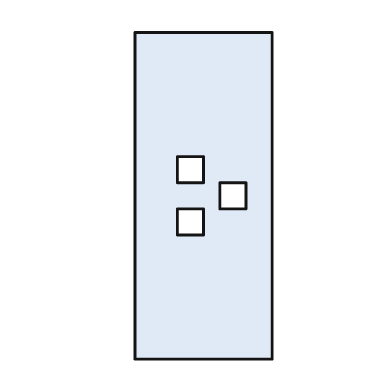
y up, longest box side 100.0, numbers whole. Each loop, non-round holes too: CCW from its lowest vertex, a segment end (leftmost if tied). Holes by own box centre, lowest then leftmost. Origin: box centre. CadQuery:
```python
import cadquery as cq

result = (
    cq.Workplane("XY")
    .moveTo(-21.0, -50.0)
    .lineTo(21.0, -50.0)
    .lineTo(21.0, 50.0)
    .lineTo(-21.0, 50.0)
    .close()
    .moveTo(-8.0, -12.0)
    .lineTo(0.0, -12.0)
    .lineTo(0.0, -4.0)
    .lineTo(-8.0, -4.0)
    .close()
    .moveTo(5.0, -4.0)
    .lineTo(13.0, -4.0)
    .lineTo(13.0, 4.0)
    .lineTo(5.0, 4.0)
    .close()
    .moveTo(-8.0, 4.0)
    .lineTo(0.0, 4.0)
    .lineTo(0.0, 12.0)
    .lineTo(-8.0, 12.0)
    .close()
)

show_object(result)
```